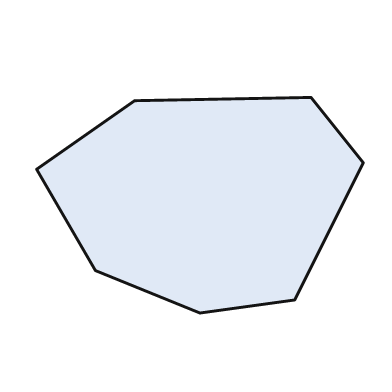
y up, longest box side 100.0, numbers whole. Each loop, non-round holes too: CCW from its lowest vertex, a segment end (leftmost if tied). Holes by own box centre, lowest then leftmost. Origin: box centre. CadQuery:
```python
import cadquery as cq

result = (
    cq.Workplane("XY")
    .moveTo(0.0, -33.0)
    .lineTo(29.0, -29.0)
    .lineTo(50.0, 13.0)
    .lineTo(34.0, 33.0)
    .lineTo(-20.0, 32.0)
    .lineTo(-50.0, 11.0)
    .lineTo(-32.0, -20.0)
    .close()
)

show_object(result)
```